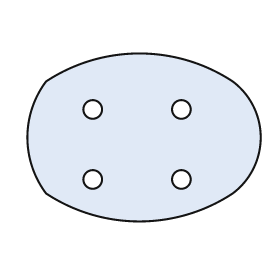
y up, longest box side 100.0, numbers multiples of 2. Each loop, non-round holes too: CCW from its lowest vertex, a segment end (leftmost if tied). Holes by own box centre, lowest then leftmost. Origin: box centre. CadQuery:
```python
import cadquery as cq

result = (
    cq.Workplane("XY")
    .moveTo(-42.0, -24.0)
    .threePointArc((-2.0, -36.0), (38.0, -24.0))
    .threePointArc((50.0, 0.0), (38.0, 24.0))
    .threePointArc((-2.0, 36.0), (-42.0, 24.0))
    .threePointArc((-50.0, 0.0), (-42.0, -24.0))
    .close()
    .moveTo(-22.0, -18.0)
    .circle(4.0)
    .moveTo(16.0, -18.0)
    .circle(4.0)
    .moveTo(-22.0, 12.0)
    .circle(4.0)
    .moveTo(16.0, 12.0)
    .circle(4.0)
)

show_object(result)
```